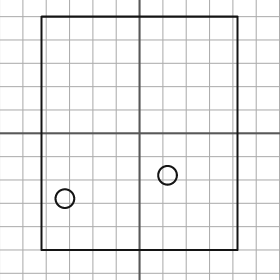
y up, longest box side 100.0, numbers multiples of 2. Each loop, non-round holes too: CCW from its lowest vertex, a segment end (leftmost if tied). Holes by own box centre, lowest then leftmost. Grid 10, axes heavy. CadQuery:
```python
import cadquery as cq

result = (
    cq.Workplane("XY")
    .moveTo(-42.0, -50.0)
    .lineTo(42.0, -50.0)
    .lineTo(42.0, 50.0)
    .lineTo(-42.0, 50.0)
    .close()
    .moveTo(-32.0, -28.0)
    .circle(4.0)
    .moveTo(12.0, -18.0)
    .circle(4.0)
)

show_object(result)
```